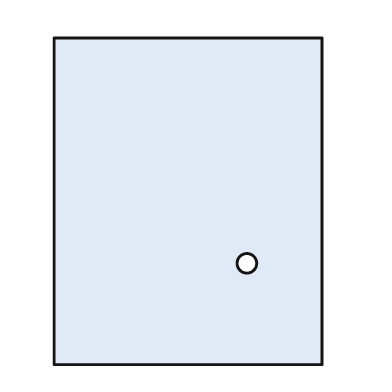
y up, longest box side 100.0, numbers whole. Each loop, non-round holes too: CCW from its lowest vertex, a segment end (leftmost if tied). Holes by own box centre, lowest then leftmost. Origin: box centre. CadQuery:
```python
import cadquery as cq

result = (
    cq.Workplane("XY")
    .moveTo(-41.0, -50.0)
    .lineTo(41.0, -50.0)
    .lineTo(41.0, 50.0)
    .lineTo(-41.0, 50.0)
    .close()
    .moveTo(18.0, -19.0)
    .circle(3.0)
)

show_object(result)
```